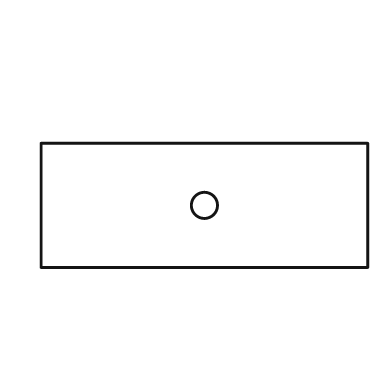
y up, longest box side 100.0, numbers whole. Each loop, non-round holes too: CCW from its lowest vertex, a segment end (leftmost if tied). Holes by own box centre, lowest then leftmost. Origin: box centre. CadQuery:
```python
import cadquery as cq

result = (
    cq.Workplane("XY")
    .moveTo(-50.0, -19.0)
    .lineTo(50.0, -19.0)
    .lineTo(50.0, 19.0)
    .lineTo(-50.0, 19.0)
    .close()
    .moveTo(0.0, 0.0)
    .circle(4.0)
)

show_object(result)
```